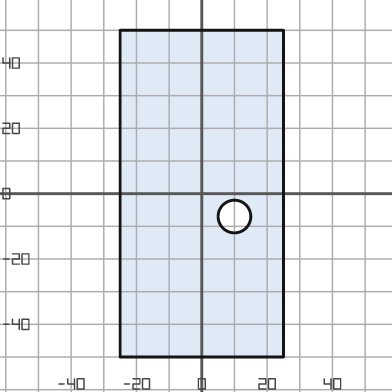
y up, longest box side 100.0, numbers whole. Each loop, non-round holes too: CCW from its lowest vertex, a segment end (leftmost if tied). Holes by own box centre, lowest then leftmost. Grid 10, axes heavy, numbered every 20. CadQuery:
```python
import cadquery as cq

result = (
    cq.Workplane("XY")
    .moveTo(-25.0, -50.0)
    .lineTo(25.0, -50.0)
    .lineTo(25.0, 50.0)
    .lineTo(-25.0, 50.0)
    .close()
    .moveTo(10.0, -7.0)
    .circle(5.0)
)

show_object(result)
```